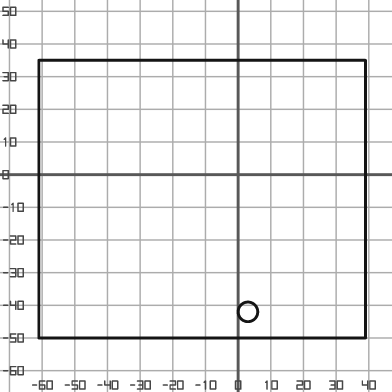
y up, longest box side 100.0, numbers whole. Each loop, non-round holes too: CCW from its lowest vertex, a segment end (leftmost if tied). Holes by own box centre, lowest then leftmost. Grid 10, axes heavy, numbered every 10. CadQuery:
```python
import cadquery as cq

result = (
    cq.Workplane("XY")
    .moveTo(-61.0, -50.0)
    .lineTo(39.0, -50.0)
    .lineTo(39.0, 35.0)
    .lineTo(-61.0, 35.0)
    .close()
    .moveTo(3.0, -42.0)
    .circle(3.0)
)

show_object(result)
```